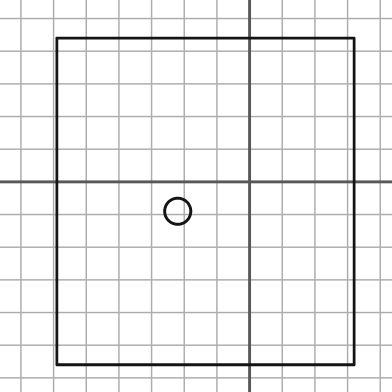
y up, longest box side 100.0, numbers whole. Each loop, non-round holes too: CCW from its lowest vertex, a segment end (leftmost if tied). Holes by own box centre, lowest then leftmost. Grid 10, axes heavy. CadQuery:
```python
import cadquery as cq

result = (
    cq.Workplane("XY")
    .moveTo(-59.0, -56.0)
    .lineTo(32.0, -56.0)
    .lineTo(32.0, 44.0)
    .lineTo(-59.0, 44.0)
    .close()
    .moveTo(-22.0, -9.0)
    .circle(4.0)
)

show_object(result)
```